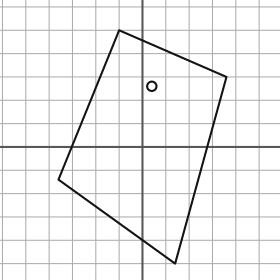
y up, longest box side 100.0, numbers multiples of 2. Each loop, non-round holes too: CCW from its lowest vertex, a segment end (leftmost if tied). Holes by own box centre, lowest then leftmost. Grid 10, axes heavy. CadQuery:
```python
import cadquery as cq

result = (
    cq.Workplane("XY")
    .moveTo(14.0, -50.0)
    .lineTo(36.0, 30.0)
    .lineTo(-10.0, 50.0)
    .lineTo(-36.0, -14.0)
    .close()
    .moveTo(4.0, 26.0)
    .circle(2.0)
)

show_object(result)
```